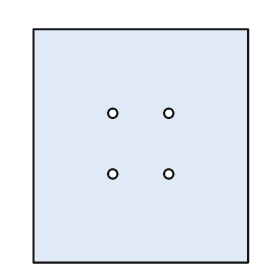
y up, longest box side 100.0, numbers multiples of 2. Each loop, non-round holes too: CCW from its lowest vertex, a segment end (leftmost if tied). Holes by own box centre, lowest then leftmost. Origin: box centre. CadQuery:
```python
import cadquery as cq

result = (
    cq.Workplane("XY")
    .moveTo(-46.0, -50.0)
    .lineTo(46.0, -50.0)
    .lineTo(46.0, 50.0)
    .lineTo(-46.0, 50.0)
    .close()
    .moveTo(-12.0, -12.0)
    .circle(2.0)
    .moveTo(12.0, -12.0)
    .circle(2.0)
    .moveTo(-12.0, 14.0)
    .circle(2.0)
    .moveTo(12.0, 14.0)
    .circle(2.0)
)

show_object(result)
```